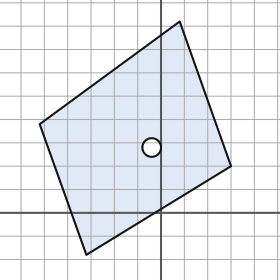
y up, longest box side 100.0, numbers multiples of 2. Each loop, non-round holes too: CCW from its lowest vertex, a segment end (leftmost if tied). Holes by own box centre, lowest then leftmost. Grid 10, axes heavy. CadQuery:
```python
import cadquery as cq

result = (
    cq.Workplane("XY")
    .moveTo(-32.0, -18.0)
    .lineTo(30.0, 20.0)
    .lineTo(8.0, 82.0)
    .lineTo(-52.0, 38.0)
    .close()
    .moveTo(-4.0, 28.0)
    .circle(4.0)
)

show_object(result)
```